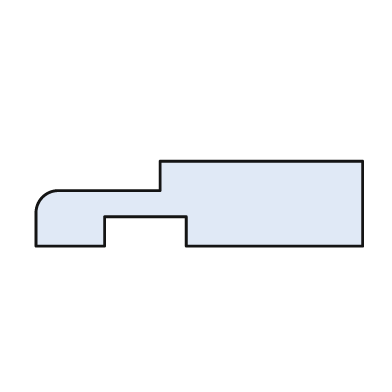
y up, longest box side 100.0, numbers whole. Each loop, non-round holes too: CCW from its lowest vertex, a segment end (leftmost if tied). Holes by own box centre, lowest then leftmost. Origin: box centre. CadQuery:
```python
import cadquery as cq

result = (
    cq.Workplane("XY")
    .moveTo(-50.0, -13.0)
    .lineTo(-29.0, -13.0)
    .lineTo(-29.0, -4.0)
    .lineTo(-4.0, -4.0)
    .lineTo(-4.0, -13.0)
    .lineTo(50.0, -13.0)
    .lineTo(50.0, 13.0)
    .lineTo(-12.0, 13.0)
    .lineTo(-12.0, 4.0)
    .lineTo(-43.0, 4.0)
    .threePointArc((-48.0, 2.0), (-50.0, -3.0))
    .close()
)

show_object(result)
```